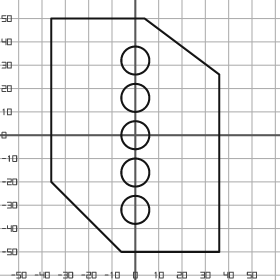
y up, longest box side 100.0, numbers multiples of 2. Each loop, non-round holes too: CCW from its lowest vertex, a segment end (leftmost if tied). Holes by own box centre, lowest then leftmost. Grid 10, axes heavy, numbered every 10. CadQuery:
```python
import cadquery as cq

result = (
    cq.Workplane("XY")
    .moveTo(-6.0, -50.0)
    .lineTo(36.0, -50.0)
    .lineTo(36.0, 26.0)
    .lineTo(4.0, 50.0)
    .lineTo(-36.0, 50.0)
    .lineTo(-36.0, -20.0)
    .close()
    .moveTo(0.0, -32.0)
    .circle(6.0)
    .moveTo(0.0, -16.0)
    .circle(6.0)
    .moveTo(0.0, 0.0)
    .circle(6.0)
    .moveTo(0.0, 16.0)
    .circle(6.0)
    .moveTo(0.0, 32.0)
    .circle(6.0)
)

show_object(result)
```